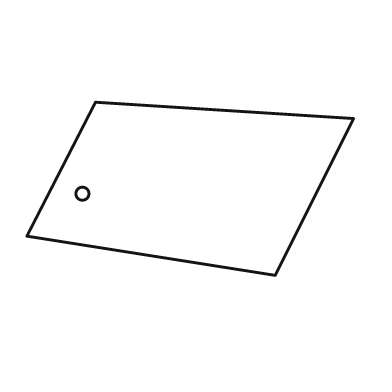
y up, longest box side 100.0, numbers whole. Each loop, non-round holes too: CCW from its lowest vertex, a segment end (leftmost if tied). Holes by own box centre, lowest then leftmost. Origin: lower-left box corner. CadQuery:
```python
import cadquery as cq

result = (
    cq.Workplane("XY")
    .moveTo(76.0, 0.0)
    .lineTo(100.0, 48.0)
    .lineTo(21.0, 53.0)
    .lineTo(0.0, 12.0)
    .close()
    .moveTo(17.0, 25.0)
    .circle(2.0)
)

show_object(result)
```